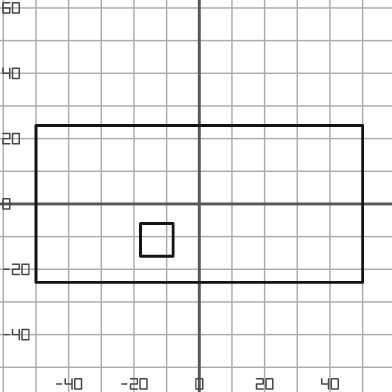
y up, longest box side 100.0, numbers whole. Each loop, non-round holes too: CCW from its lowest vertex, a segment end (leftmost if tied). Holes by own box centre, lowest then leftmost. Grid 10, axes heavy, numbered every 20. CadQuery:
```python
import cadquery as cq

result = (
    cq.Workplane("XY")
    .moveTo(-50.0, -24.0)
    .lineTo(50.0, -24.0)
    .lineTo(50.0, 24.0)
    .lineTo(-50.0, 24.0)
    .close()
    .moveTo(-18.0, -16.0)
    .lineTo(-8.0, -16.0)
    .lineTo(-8.0, -6.0)
    .lineTo(-18.0, -6.0)
    .close()
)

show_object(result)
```